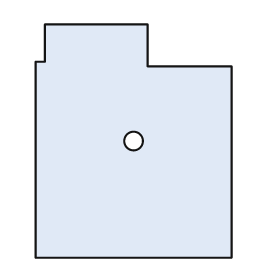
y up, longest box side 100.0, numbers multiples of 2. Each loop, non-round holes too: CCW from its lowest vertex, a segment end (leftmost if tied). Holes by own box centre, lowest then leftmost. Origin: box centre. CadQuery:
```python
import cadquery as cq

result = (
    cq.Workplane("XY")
    .moveTo(-42.0, -50.0)
    .lineTo(42.0, -50.0)
    .lineTo(42.0, 32.0)
    .lineTo(6.0, 32.0)
    .lineTo(6.0, 50.0)
    .lineTo(-38.0, 50.0)
    .lineTo(-38.0, 34.0)
    .lineTo(-42.0, 34.0)
    .close()
    .moveTo(0.0, 0.0)
    .circle(4.0)
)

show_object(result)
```